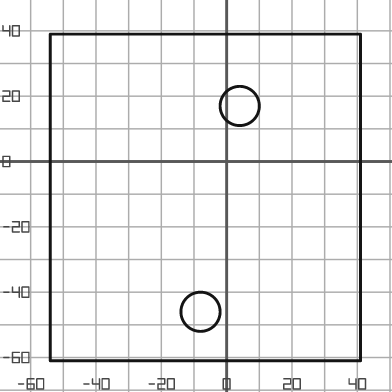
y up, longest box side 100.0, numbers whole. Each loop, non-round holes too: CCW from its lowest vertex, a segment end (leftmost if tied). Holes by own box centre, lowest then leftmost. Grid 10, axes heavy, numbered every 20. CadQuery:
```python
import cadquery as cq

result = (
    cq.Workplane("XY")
    .moveTo(-54.0, -61.0)
    .lineTo(41.0, -61.0)
    .lineTo(41.0, 39.0)
    .lineTo(-54.0, 39.0)
    .close()
    .moveTo(-8.0, -46.0)
    .circle(6.0)
    .moveTo(4.0, 17.0)
    .circle(6.0)
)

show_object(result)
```